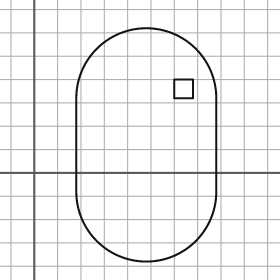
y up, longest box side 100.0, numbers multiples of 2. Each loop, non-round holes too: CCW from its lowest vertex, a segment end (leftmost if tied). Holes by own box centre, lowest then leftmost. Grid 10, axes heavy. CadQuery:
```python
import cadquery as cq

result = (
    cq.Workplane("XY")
    .moveTo(18.0, -8.0)
    .threePointArc((48.0, -38.0), (78.0, -8.0))
    .lineTo(78.0, 32.0)
    .threePointArc((48.0, 62.0), (18.0, 32.0))
    .close()
    .moveTo(60.0, 32.0)
    .lineTo(68.0, 32.0)
    .lineTo(68.0, 40.0)
    .lineTo(60.0, 40.0)
    .close()
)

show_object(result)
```